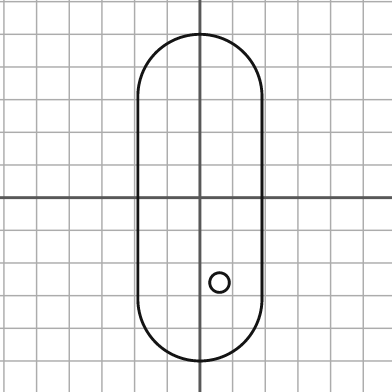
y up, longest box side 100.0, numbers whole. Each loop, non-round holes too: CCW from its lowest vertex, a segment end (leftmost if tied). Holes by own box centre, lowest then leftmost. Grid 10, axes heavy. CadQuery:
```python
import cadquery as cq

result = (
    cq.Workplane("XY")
    .moveTo(-19.0, -31.0)
    .threePointArc((0.0, -50.0), (19.0, -31.0))
    .lineTo(19.0, 31.0)
    .threePointArc((0.0, 50.0), (-19.0, 31.0))
    .close()
    .moveTo(6.0, -26.0)
    .circle(3.0)
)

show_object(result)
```